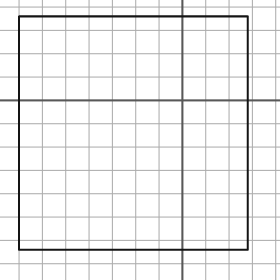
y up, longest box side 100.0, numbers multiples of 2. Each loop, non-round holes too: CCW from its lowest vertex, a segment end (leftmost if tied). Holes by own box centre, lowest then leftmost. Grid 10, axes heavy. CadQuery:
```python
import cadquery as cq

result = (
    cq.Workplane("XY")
    .moveTo(-70.0, -64.0)
    .lineTo(28.0, -64.0)
    .lineTo(28.0, 36.0)
    .lineTo(-70.0, 36.0)
    .close()
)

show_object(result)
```